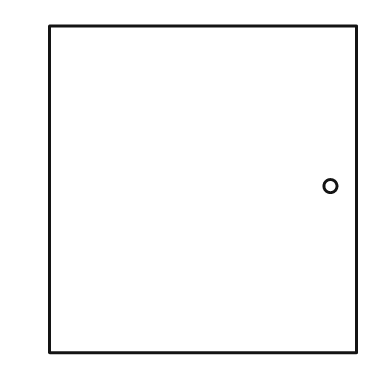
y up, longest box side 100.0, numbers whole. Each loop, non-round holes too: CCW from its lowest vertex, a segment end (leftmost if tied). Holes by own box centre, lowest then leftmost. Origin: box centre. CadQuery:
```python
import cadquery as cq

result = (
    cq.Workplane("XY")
    .moveTo(-47.0, -50.0)
    .lineTo(47.0, -50.0)
    .lineTo(47.0, 50.0)
    .lineTo(-47.0, 50.0)
    .close()
    .moveTo(39.0, 1.0)
    .circle(2.0)
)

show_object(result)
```